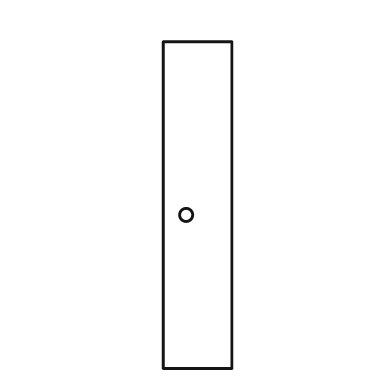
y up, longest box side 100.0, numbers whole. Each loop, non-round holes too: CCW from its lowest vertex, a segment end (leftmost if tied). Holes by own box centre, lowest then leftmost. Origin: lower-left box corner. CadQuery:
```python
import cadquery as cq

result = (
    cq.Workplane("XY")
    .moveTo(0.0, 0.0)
    .lineTo(21.0, 0.0)
    .lineTo(21.0, 100.0)
    .lineTo(0.0, 100.0)
    .close()
    .moveTo(7.0, 47.0)
    .circle(2.0)
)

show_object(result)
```